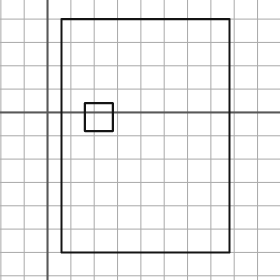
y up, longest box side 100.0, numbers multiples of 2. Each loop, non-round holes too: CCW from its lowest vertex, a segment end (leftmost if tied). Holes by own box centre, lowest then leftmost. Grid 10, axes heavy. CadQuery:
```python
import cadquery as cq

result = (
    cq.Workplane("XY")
    .moveTo(6.0, -60.0)
    .lineTo(78.0, -60.0)
    .lineTo(78.0, 40.0)
    .lineTo(6.0, 40.0)
    .close()
    .moveTo(16.0, -8.0)
    .lineTo(28.0, -8.0)
    .lineTo(28.0, 4.0)
    .lineTo(16.0, 4.0)
    .close()
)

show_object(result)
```